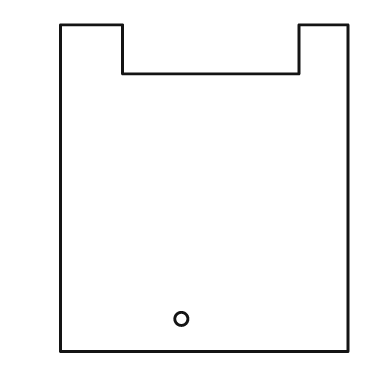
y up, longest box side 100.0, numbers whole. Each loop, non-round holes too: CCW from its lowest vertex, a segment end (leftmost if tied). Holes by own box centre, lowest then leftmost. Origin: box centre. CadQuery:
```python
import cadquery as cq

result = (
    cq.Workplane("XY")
    .moveTo(-44.0, -50.0)
    .lineTo(44.0, -50.0)
    .lineTo(44.0, 50.0)
    .lineTo(29.0, 50.0)
    .lineTo(29.0, 35.0)
    .lineTo(-25.0, 35.0)
    .lineTo(-25.0, 50.0)
    .lineTo(-44.0, 50.0)
    .close()
    .moveTo(-7.0, -40.0)
    .circle(2.0)
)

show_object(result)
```